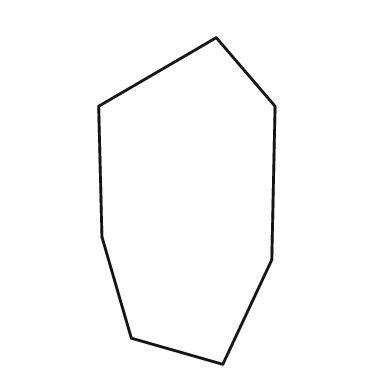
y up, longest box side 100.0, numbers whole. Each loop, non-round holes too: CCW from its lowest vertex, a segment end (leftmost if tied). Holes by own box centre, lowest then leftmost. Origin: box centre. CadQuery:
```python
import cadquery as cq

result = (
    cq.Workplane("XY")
    .moveTo(11.0, -50.0)
    .lineTo(26.0, -18.0)
    .lineTo(27.0, 29.0)
    .lineTo(9.0, 50.0)
    .lineTo(-27.0, 29.0)
    .lineTo(-26.0, -11.0)
    .lineTo(-17.0, -42.0)
    .close()
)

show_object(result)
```